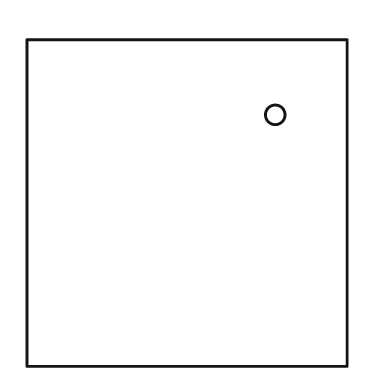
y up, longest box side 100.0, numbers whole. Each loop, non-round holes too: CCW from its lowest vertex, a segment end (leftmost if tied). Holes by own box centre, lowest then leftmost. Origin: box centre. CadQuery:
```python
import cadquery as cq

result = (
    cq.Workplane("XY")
    .moveTo(-49.0, -50.0)
    .lineTo(49.0, -50.0)
    .lineTo(49.0, 50.0)
    .lineTo(-49.0, 50.0)
    .close()
    .moveTo(27.0, 27.0)
    .circle(3.0)
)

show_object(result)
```